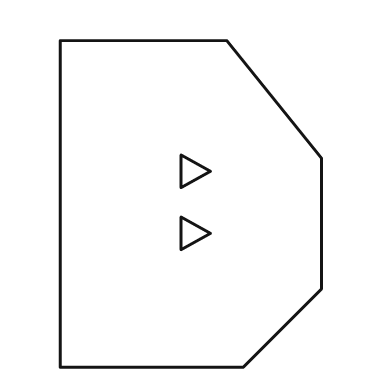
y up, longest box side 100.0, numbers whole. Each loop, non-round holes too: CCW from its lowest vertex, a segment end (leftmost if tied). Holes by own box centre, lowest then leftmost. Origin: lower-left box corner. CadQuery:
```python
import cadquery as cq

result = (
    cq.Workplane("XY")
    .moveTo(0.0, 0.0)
    .lineTo(56.0, 0.0)
    .lineTo(80.0, 24.0)
    .lineTo(80.0, 64.0)
    .lineTo(51.0, 100.0)
    .lineTo(0.0, 100.0)
    .close()
    .moveTo(37.0, 36.0)
    .lineTo(46.0, 41.0)
    .lineTo(37.0, 46.0)
    .close()
    .moveTo(37.0, 55.0)
    .lineTo(46.0, 60.0)
    .lineTo(37.0, 65.0)
    .close()
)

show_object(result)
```